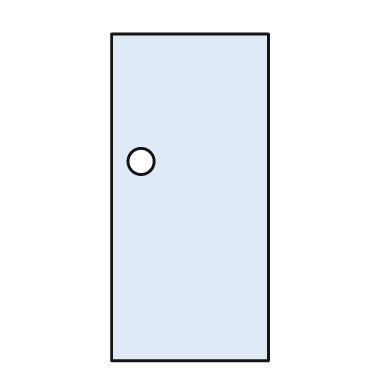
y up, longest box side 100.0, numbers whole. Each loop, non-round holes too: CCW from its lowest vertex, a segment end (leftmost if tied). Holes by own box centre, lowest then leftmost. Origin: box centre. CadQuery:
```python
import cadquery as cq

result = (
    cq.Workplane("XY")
    .moveTo(-24.0, -50.0)
    .lineTo(24.0, -50.0)
    .lineTo(24.0, 50.0)
    .lineTo(-24.0, 50.0)
    .close()
    .moveTo(-15.0, 11.0)
    .circle(4.0)
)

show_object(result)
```